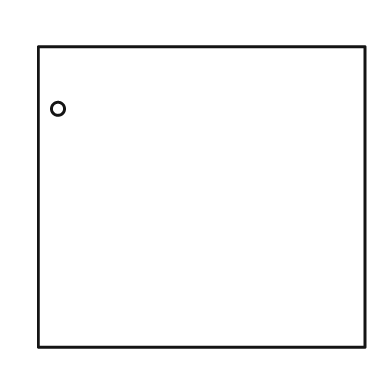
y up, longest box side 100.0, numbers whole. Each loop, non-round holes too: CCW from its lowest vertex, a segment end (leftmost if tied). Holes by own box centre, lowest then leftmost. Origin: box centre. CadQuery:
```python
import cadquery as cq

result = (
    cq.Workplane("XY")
    .moveTo(-50.0, -46.0)
    .lineTo(50.0, -46.0)
    .lineTo(50.0, 46.0)
    .lineTo(-50.0, 46.0)
    .close()
    .moveTo(-44.0, 27.0)
    .circle(2.0)
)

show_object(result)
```